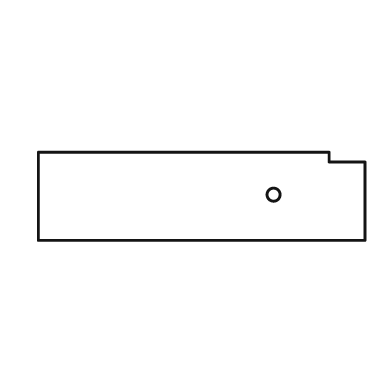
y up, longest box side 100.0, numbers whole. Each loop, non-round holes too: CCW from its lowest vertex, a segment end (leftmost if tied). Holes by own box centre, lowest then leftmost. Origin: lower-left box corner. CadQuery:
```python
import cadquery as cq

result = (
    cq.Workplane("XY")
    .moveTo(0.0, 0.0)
    .lineTo(100.0, 0.0)
    .lineTo(100.0, 24.0)
    .lineTo(89.0, 24.0)
    .lineTo(89.0, 27.0)
    .lineTo(0.0, 27.0)
    .close()
    .moveTo(72.0, 14.0)
    .circle(2.0)
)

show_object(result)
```